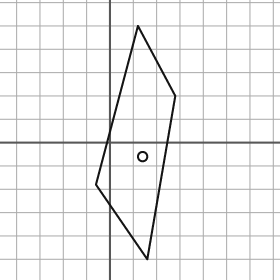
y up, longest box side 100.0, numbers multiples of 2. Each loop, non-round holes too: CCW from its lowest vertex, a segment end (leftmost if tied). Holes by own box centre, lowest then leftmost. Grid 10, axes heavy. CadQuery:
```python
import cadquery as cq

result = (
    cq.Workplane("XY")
    .moveTo(16.0, -50.0)
    .lineTo(28.0, 20.0)
    .lineTo(12.0, 50.0)
    .lineTo(-6.0, -18.0)
    .close()
    .moveTo(14.0, -6.0)
    .circle(2.0)
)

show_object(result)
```